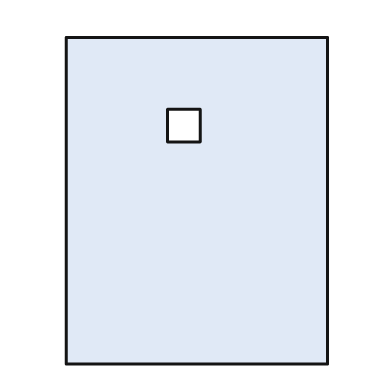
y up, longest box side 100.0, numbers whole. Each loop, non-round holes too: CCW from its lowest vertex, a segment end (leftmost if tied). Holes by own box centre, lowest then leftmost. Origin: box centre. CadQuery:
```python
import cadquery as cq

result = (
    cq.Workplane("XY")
    .moveTo(-40.0, -50.0)
    .lineTo(40.0, -50.0)
    .lineTo(40.0, 50.0)
    .lineTo(-40.0, 50.0)
    .close()
    .moveTo(-9.0, 18.0)
    .lineTo(1.0, 18.0)
    .lineTo(1.0, 28.0)
    .lineTo(-9.0, 28.0)
    .close()
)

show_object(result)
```